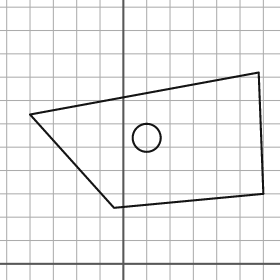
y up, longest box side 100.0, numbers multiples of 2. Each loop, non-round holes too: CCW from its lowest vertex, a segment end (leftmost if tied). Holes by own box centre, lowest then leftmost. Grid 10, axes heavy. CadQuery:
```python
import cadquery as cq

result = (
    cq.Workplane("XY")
    .moveTo(-4.0, 24.0)
    .lineTo(60.0, 30.0)
    .lineTo(58.0, 82.0)
    .lineTo(-40.0, 64.0)
    .close()
    .moveTo(10.0, 54.0)
    .circle(6.0)
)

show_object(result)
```